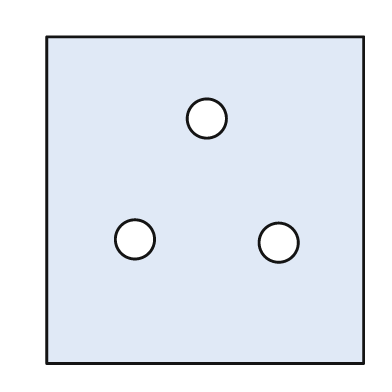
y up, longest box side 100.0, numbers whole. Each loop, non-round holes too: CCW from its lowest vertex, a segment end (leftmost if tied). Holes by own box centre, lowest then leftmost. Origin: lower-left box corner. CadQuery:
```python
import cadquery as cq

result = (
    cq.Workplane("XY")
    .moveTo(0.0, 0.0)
    .lineTo(97.0, 0.0)
    .lineTo(97.0, 100.0)
    .lineTo(0.0, 100.0)
    .close()
    .moveTo(71.0, 37.0)
    .circle(6.0)
    .moveTo(27.0, 38.0)
    .circle(6.0)
    .moveTo(49.0, 75.0)
    .circle(6.0)
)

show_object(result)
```